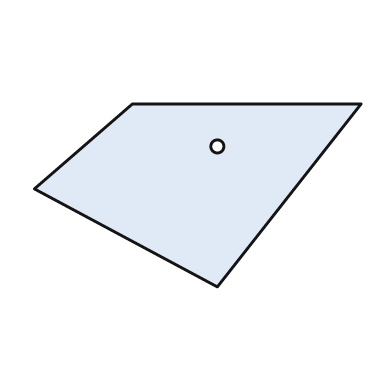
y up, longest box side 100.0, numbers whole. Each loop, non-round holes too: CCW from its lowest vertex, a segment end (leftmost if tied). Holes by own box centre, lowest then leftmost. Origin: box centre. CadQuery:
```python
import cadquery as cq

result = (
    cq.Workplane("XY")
    .moveTo(6.0, -28.0)
    .lineTo(50.0, 28.0)
    .lineTo(-20.0, 28.0)
    .lineTo(-50.0, 2.0)
    .close()
    .moveTo(6.0, 15.0)
    .circle(2.0)
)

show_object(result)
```